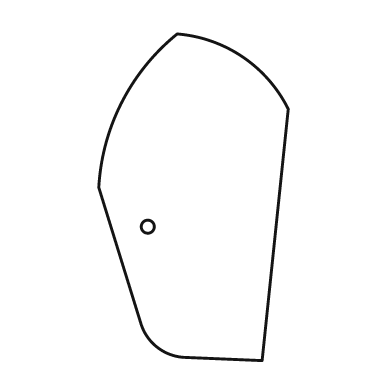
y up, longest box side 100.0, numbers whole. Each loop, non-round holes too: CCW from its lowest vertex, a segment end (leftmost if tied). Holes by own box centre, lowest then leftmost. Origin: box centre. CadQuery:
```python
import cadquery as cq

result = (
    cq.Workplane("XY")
    .moveTo(21.0, -50.0)
    .lineTo(29.0, 27.0)
    .threePointArc((15.0, 43.0), (-5.0, 50.0))
    .threePointArc((-22.0, 29.0), (-29.0, 3.0))
    .lineTo(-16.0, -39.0)
    .threePointArc((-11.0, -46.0), (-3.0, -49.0))
    .close()
    .moveTo(-14.0, -9.0)
    .circle(2.0)
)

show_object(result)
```